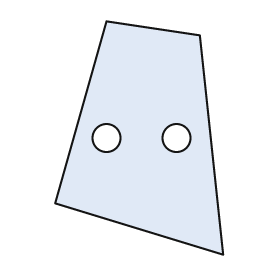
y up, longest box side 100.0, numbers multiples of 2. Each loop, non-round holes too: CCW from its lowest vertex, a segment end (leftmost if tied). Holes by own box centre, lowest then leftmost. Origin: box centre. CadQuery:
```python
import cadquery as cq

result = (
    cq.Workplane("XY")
    .moveTo(36.0, -50.0)
    .lineTo(26.0, 44.0)
    .lineTo(-14.0, 50.0)
    .lineTo(-36.0, -28.0)
    .close()
    .moveTo(-14.0, 0.0)
    .circle(6.0)
    .moveTo(16.0, 0.0)
    .circle(6.0)
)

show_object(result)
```